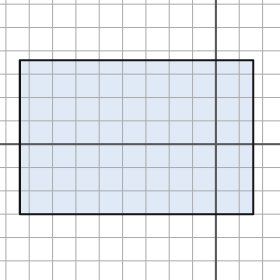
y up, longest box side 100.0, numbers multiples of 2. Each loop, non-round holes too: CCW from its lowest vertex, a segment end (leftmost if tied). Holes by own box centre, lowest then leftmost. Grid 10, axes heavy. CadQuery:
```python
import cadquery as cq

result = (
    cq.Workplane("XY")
    .moveTo(-84.0, -30.0)
    .lineTo(16.0, -30.0)
    .lineTo(16.0, 36.0)
    .lineTo(-84.0, 36.0)
    .close()
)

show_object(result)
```